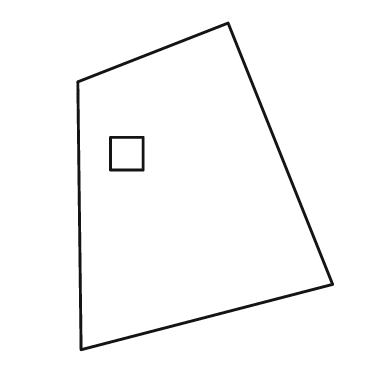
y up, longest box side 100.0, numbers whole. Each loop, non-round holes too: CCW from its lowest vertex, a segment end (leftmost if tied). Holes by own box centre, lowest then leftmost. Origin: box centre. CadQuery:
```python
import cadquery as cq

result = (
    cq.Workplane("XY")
    .moveTo(-38.0, -50.0)
    .lineTo(39.0, -30.0)
    .lineTo(7.0, 50.0)
    .lineTo(-39.0, 32.0)
    .close()
    .moveTo(-29.0, 5.0)
    .lineTo(-19.0, 5.0)
    .lineTo(-19.0, 15.0)
    .lineTo(-29.0, 15.0)
    .close()
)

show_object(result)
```